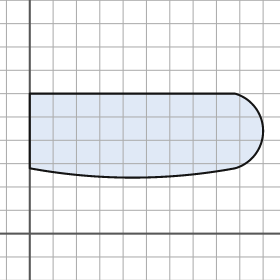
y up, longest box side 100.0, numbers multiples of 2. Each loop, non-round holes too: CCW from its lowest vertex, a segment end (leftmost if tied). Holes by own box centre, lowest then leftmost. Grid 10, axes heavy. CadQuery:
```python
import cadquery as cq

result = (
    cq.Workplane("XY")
    .moveTo(0.0, 28.0)
    .threePointArc((44.0, 24.0), (88.0, 28.0))
    .threePointArc((100.0, 44.0), (88.0, 60.0))
    .lineTo(0.0, 60.0)
    .close()
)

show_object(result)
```